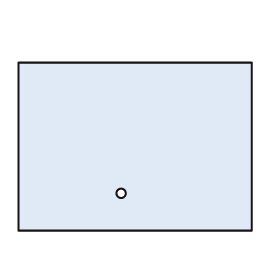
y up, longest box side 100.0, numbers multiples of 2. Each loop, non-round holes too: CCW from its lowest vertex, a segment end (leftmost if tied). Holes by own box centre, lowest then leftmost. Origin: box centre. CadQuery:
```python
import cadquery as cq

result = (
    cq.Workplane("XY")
    .moveTo(-50.0, -36.0)
    .lineTo(50.0, -36.0)
    .lineTo(50.0, 36.0)
    .lineTo(-50.0, 36.0)
    .close()
    .moveTo(-6.0, -20.0)
    .circle(2.0)
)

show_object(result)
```